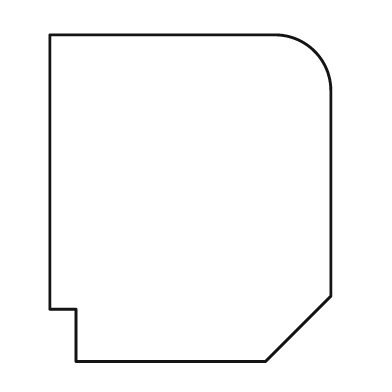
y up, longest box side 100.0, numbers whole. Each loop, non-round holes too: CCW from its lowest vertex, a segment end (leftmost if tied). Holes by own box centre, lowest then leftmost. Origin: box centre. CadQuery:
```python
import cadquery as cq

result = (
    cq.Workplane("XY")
    .moveTo(-35.0, -50.0)
    .lineTo(23.0, -50.0)
    .lineTo(43.0, -30.0)
    .lineTo(43.0, 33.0)
    .threePointArc((38.0, 45.0), (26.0, 50.0))
    .lineTo(-43.0, 50.0)
    .lineTo(-43.0, -34.0)
    .lineTo(-35.0, -34.0)
    .close()
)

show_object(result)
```